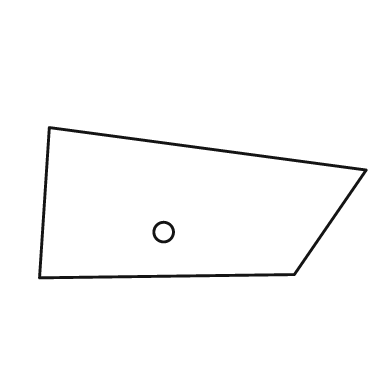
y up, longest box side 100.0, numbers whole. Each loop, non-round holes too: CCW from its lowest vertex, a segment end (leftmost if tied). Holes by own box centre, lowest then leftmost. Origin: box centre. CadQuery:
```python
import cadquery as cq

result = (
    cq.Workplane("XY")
    .moveTo(-50.0, -23.0)
    .lineTo(28.0, -22.0)
    .lineTo(50.0, 10.0)
    .lineTo(-47.0, 23.0)
    .close()
    .moveTo(-12.0, -9.0)
    .circle(3.0)
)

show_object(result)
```